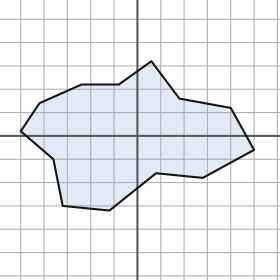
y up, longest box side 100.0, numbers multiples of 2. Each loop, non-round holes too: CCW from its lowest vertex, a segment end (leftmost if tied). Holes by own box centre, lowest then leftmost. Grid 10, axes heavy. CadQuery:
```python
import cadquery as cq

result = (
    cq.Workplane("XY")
    .moveTo(-12.0, -32.0)
    .lineTo(8.0, -16.0)
    .lineTo(28.0, -18.0)
    .lineTo(50.0, -6.0)
    .lineTo(40.0, 12.0)
    .lineTo(18.0, 16.0)
    .lineTo(6.0, 32.0)
    .lineTo(-8.0, 22.0)
    .lineTo(-24.0, 22.0)
    .lineTo(-42.0, 14.0)
    .lineTo(-50.0, 2.0)
    .lineTo(-36.0, -10.0)
    .lineTo(-32.0, -30.0)
    .close()
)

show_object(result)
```